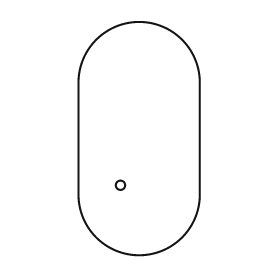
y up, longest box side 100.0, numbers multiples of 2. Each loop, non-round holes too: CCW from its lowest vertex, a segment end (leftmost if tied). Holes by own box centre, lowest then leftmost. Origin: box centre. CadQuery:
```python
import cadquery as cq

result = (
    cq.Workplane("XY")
    .moveTo(-26.0, -24.0)
    .threePointArc((0.0, -50.0), (26.0, -24.0))
    .lineTo(26.0, 24.0)
    .threePointArc((0.0, 50.0), (-26.0, 24.0))
    .close()
    .moveTo(-8.0, -20.0)
    .circle(2.0)
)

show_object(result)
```